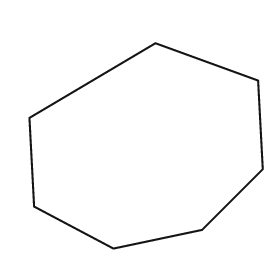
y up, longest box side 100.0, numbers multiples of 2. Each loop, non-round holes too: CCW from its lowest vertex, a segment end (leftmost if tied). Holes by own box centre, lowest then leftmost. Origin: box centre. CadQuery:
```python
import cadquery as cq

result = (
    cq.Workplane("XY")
    .moveTo(-14.0, -44.0)
    .lineTo(24.0, -36.0)
    .lineTo(50.0, -10.0)
    .lineTo(48.0, 28.0)
    .lineTo(4.0, 44.0)
    .lineTo(-50.0, 12.0)
    .lineTo(-48.0, -26.0)
    .close()
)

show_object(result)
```